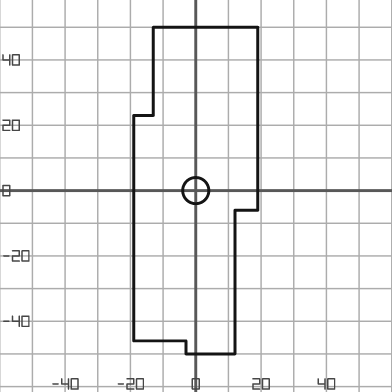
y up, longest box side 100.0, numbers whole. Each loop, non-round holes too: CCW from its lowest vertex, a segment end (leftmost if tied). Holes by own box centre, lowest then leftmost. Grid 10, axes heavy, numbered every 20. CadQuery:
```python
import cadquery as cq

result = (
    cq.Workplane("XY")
    .moveTo(-3.0, -50.0)
    .lineTo(12.0, -50.0)
    .lineTo(12.0, -6.0)
    .lineTo(19.0, -6.0)
    .lineTo(19.0, 50.0)
    .lineTo(-13.0, 50.0)
    .lineTo(-13.0, 23.0)
    .lineTo(-19.0, 23.0)
    .lineTo(-19.0, -46.0)
    .lineTo(-3.0, -46.0)
    .close()
    .moveTo(0.0, 0.0)
    .circle(4.0)
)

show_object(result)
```